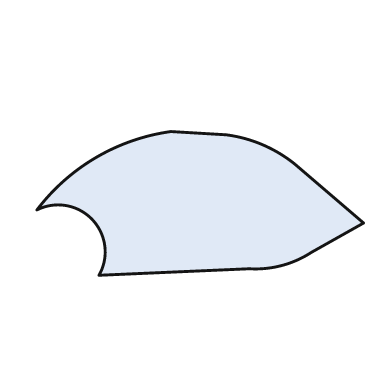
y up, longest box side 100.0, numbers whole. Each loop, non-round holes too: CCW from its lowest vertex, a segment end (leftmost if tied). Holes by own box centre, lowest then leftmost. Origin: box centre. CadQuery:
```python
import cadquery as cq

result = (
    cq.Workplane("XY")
    .moveTo(-31.0, -22.0)
    .lineTo(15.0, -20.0)
    .threePointArc((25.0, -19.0), (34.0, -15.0))
    .lineTo(50.0, -6.0)
    .lineTo(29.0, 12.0)
    .threePointArc((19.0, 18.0), (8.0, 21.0))
    .lineTo(-9.0, 22.0)
    .threePointArc((-32.0, 14.0), (-50.0, -2.0))
    .threePointArc((-33.0, -5.0), (-31.0, -22.0))
    .close()
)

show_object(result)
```